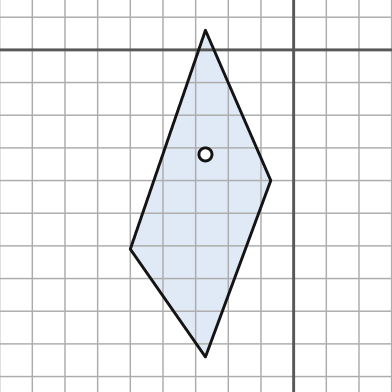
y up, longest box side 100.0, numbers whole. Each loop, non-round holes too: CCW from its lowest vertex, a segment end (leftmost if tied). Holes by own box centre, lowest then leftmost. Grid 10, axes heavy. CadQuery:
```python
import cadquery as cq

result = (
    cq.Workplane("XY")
    .moveTo(-27.0, -94.0)
    .lineTo(-7.0, -40.0)
    .lineTo(-27.0, 6.0)
    .lineTo(-50.0, -61.0)
    .close()
    .moveTo(-27.0, -32.0)
    .circle(2.0)
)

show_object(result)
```